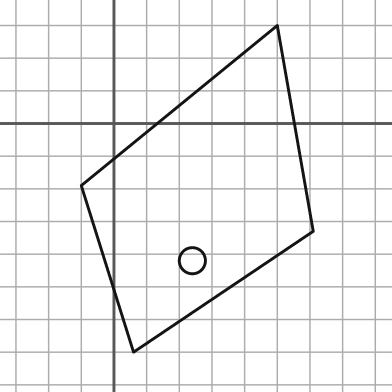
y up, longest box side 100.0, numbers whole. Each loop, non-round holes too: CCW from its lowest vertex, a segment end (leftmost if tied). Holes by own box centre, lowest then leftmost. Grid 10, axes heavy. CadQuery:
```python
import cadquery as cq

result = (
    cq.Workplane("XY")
    .moveTo(6.0, -70.0)
    .lineTo(61.0, -33.0)
    .lineTo(50.0, 30.0)
    .lineTo(-10.0, -19.0)
    .close()
    .moveTo(24.0, -42.0)
    .circle(4.0)
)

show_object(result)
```